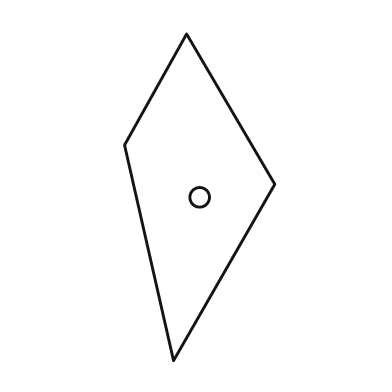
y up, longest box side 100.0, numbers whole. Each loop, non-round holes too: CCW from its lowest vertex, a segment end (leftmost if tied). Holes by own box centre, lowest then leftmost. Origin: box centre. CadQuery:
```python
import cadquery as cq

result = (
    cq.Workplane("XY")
    .moveTo(-8.0, -50.0)
    .lineTo(23.0, 4.0)
    .lineTo(-4.0, 50.0)
    .lineTo(-23.0, 16.0)
    .close()
    .moveTo(0.0, 0.0)
    .circle(3.0)
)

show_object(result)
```